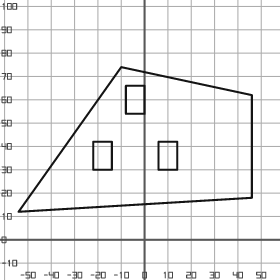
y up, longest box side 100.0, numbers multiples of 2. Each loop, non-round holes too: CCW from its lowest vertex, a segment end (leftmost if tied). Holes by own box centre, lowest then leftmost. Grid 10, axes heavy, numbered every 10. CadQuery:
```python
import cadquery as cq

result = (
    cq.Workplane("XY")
    .moveTo(-54.0, 12.0)
    .lineTo(46.0, 18.0)
    .lineTo(46.0, 62.0)
    .lineTo(-10.0, 74.0)
    .close()
    .moveTo(-22.0, 30.0)
    .lineTo(-14.0, 30.0)
    .lineTo(-14.0, 42.0)
    .lineTo(-22.0, 42.0)
    .close()
    .moveTo(6.0, 30.0)
    .lineTo(14.0, 30.0)
    .lineTo(14.0, 42.0)
    .lineTo(6.0, 42.0)
    .close()
    .moveTo(-8.0, 54.0)
    .lineTo(0.0, 54.0)
    .lineTo(0.0, 66.0)
    .lineTo(-8.0, 66.0)
    .close()
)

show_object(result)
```